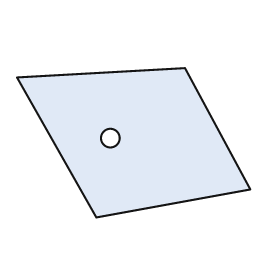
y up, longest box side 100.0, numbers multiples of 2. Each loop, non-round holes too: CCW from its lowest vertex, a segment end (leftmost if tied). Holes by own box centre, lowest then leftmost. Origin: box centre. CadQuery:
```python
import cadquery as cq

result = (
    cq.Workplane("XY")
    .moveTo(-16.0, -32.0)
    .lineTo(50.0, -20.0)
    .lineTo(22.0, 32.0)
    .lineTo(-50.0, 28.0)
    .close()
    .moveTo(-10.0, 2.0)
    .circle(4.0)
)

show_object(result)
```